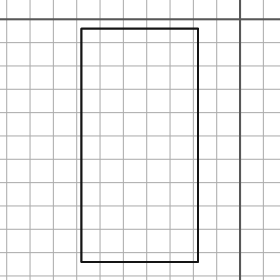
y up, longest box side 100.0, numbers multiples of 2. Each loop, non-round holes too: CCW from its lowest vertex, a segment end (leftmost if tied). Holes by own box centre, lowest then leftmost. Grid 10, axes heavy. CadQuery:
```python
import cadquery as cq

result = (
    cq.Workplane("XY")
    .moveTo(-68.0, -104.0)
    .lineTo(-18.0, -104.0)
    .lineTo(-18.0, -4.0)
    .lineTo(-68.0, -4.0)
    .close()
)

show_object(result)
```